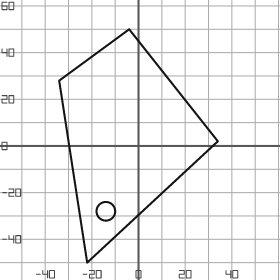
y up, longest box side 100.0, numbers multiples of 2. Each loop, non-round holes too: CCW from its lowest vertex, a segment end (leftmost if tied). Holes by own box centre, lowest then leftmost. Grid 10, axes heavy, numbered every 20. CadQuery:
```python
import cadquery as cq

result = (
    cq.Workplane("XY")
    .moveTo(-22.0, -50.0)
    .lineTo(34.0, 2.0)
    .lineTo(-4.0, 50.0)
    .lineTo(-34.0, 28.0)
    .close()
    .moveTo(-14.0, -28.0)
    .circle(4.0)
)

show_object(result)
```